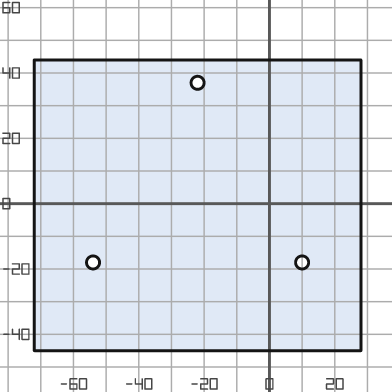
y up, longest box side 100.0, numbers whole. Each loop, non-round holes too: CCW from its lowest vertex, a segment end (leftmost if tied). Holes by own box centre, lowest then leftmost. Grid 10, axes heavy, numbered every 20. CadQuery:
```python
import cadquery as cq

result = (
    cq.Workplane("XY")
    .moveTo(-72.0, -45.0)
    .lineTo(28.0, -45.0)
    .lineTo(28.0, 44.0)
    .lineTo(-72.0, 44.0)
    .close()
    .moveTo(-54.0, -18.0)
    .circle(2.0)
    .moveTo(10.0, -18.0)
    .circle(2.0)
    .moveTo(-22.0, 37.0)
    .circle(2.0)
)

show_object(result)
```